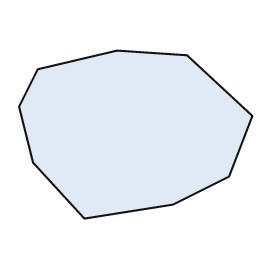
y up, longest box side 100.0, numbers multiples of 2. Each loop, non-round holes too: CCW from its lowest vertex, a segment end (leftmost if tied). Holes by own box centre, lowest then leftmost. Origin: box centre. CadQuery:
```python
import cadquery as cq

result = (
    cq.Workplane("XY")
    .moveTo(-22.0, -36.0)
    .lineTo(16.0, -30.0)
    .lineTo(40.0, -18.0)
    .lineTo(50.0, 8.0)
    .lineTo(22.0, 34.0)
    .lineTo(-8.0, 36.0)
    .lineTo(-42.0, 28.0)
    .lineTo(-50.0, 12.0)
    .lineTo(-44.0, -12.0)
    .close()
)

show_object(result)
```